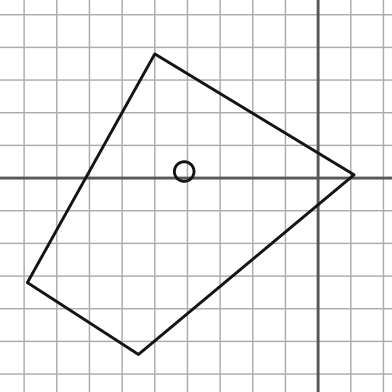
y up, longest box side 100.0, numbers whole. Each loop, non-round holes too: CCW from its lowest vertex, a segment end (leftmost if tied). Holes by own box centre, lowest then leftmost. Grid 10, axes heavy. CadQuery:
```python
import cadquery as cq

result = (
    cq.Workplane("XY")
    .moveTo(-55.0, -54.0)
    .lineTo(11.0, 1.0)
    .lineTo(-50.0, 38.0)
    .lineTo(-89.0, -32.0)
    .close()
    .moveTo(-41.0, 2.0)
    .circle(3.0)
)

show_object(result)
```